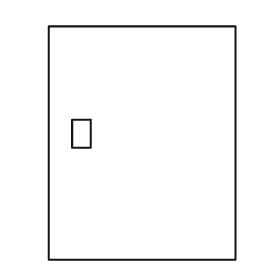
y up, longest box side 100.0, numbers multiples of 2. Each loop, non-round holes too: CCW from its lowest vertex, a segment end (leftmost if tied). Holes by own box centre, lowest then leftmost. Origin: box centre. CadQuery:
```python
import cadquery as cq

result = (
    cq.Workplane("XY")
    .moveTo(-40.0, -50.0)
    .lineTo(40.0, -50.0)
    .lineTo(40.0, 50.0)
    .lineTo(-40.0, 50.0)
    .close()
    .moveTo(-30.0, -2.0)
    .lineTo(-22.0, -2.0)
    .lineTo(-22.0, 10.0)
    .lineTo(-30.0, 10.0)
    .close()
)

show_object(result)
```